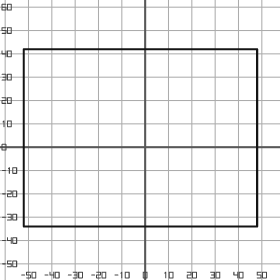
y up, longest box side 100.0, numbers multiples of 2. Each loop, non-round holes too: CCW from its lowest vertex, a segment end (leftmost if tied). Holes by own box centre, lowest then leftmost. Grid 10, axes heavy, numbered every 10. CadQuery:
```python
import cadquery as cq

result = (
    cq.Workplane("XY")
    .moveTo(-52.0, -34.0)
    .lineTo(48.0, -34.0)
    .lineTo(48.0, 42.0)
    .lineTo(-52.0, 42.0)
    .close()
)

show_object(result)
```